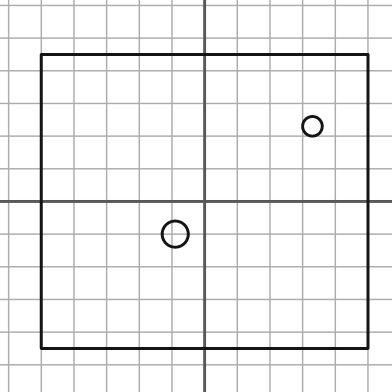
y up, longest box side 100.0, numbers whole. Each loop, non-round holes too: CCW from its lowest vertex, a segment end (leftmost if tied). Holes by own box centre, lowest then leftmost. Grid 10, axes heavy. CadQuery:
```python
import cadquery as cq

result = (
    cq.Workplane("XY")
    .moveTo(-50.0, -45.0)
    .lineTo(50.0, -45.0)
    .lineTo(50.0, 45.0)
    .lineTo(-50.0, 45.0)
    .close()
    .moveTo(-9.0, -10.0)
    .circle(4.0)
    .moveTo(33.0, 23.0)
    .circle(3.0)
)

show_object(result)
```